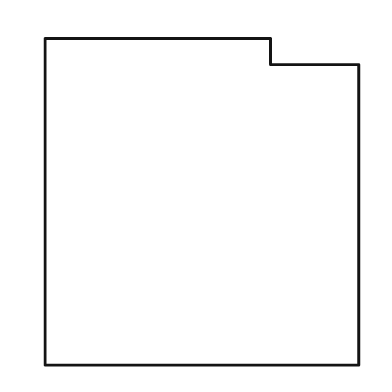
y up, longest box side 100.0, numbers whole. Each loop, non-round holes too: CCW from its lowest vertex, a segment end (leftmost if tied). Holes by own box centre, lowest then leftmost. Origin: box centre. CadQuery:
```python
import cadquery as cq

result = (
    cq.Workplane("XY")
    .moveTo(-48.0, -50.0)
    .lineTo(48.0, -50.0)
    .lineTo(48.0, 42.0)
    .lineTo(21.0, 42.0)
    .lineTo(21.0, 50.0)
    .lineTo(-48.0, 50.0)
    .close()
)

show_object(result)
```